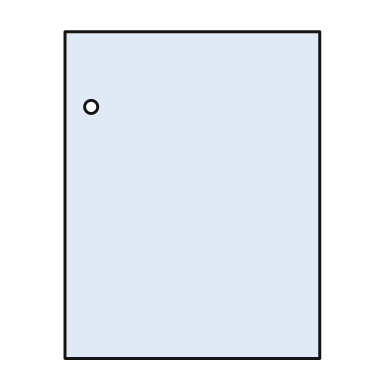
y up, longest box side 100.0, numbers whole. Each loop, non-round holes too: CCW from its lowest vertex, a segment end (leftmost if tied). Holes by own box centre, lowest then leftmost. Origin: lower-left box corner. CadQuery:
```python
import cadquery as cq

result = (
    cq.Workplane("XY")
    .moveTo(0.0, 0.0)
    .lineTo(78.0, 0.0)
    .lineTo(78.0, 100.0)
    .lineTo(0.0, 100.0)
    .close()
    .moveTo(8.0, 77.0)
    .circle(2.0)
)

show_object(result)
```